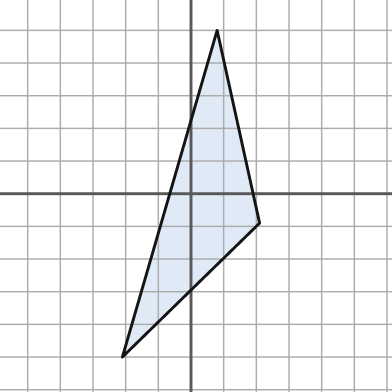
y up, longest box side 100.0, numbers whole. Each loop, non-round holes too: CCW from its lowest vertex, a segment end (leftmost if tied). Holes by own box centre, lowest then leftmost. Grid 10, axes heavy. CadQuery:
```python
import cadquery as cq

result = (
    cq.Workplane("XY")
    .moveTo(-21.0, -50.0)
    .lineTo(21.0, -9.0)
    .lineTo(8.0, 50.0)
    .close()
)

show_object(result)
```